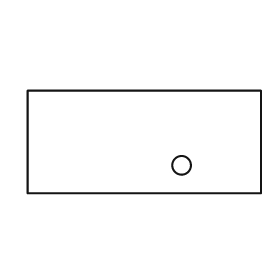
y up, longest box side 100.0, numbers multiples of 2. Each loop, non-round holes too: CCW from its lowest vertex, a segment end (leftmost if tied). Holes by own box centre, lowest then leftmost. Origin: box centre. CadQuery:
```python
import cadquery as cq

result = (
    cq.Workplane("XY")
    .moveTo(-50.0, -22.0)
    .lineTo(50.0, -22.0)
    .lineTo(50.0, 22.0)
    .lineTo(-50.0, 22.0)
    .close()
    .moveTo(16.0, -10.0)
    .circle(4.0)
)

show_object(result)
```